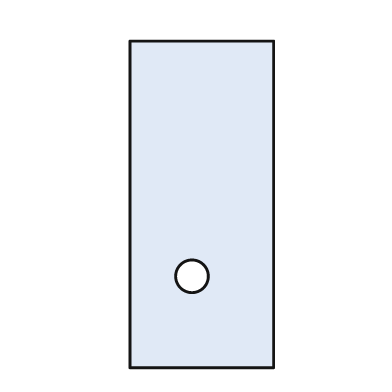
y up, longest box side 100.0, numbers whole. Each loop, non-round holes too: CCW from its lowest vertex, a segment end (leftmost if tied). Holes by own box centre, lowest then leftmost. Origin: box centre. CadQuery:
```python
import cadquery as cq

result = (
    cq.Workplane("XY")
    .moveTo(-22.0, -50.0)
    .lineTo(22.0, -50.0)
    .lineTo(22.0, 50.0)
    .lineTo(-22.0, 50.0)
    .close()
    .moveTo(-3.0, -22.0)
    .circle(5.0)
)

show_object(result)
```